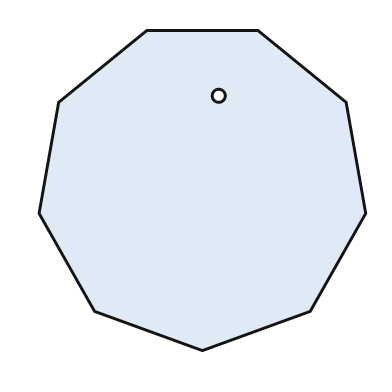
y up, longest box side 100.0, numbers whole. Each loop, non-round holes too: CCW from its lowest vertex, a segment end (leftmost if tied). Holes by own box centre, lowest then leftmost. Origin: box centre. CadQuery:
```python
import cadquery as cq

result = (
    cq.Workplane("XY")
    .moveTo(0.0, -49.0)
    .lineTo(33.0, -37.0)
    .lineTo(50.0, -7.0)
    .lineTo(44.0, 27.0)
    .lineTo(17.0, 49.0)
    .lineTo(-17.0, 49.0)
    .lineTo(-44.0, 27.0)
    .lineTo(-50.0, -7.0)
    .lineTo(-33.0, -37.0)
    .close()
    .moveTo(5.0, 29.0)
    .circle(2.0)
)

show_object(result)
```